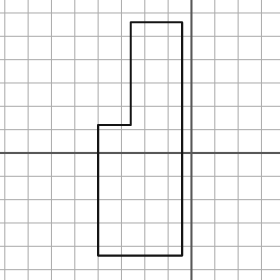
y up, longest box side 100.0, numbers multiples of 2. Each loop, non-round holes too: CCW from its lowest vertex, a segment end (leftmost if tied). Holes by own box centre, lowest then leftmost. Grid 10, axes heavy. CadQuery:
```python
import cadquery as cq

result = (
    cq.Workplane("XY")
    .moveTo(-40.0, -44.0)
    .lineTo(-4.0, -44.0)
    .lineTo(-4.0, 56.0)
    .lineTo(-26.0, 56.0)
    .lineTo(-26.0, 12.0)
    .lineTo(-40.0, 12.0)
    .close()
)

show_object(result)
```